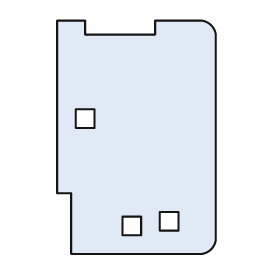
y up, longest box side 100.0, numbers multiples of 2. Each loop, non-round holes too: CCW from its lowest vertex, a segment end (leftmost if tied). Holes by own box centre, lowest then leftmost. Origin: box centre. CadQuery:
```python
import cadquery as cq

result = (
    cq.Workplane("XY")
    .moveTo(-28.0, -50.0)
    .lineTo(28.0, -50.0)
    .threePointArc((32.0, -48.0), (34.0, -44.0))
    .lineTo(34.0, 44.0)
    .threePointArc((32.0, 48.0), (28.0, 50.0))
    .lineTo(8.0, 50.0)
    .lineTo(8.0, 44.0)
    .lineTo(-22.0, 44.0)
    .lineTo(-22.0, 50.0)
    .lineTo(-34.0, 50.0)
    .lineTo(-34.0, -24.0)
    .lineTo(-28.0, -24.0)
    .close()
    .moveTo(-6.0, -42.0)
    .lineTo(2.0, -42.0)
    .lineTo(2.0, -34.0)
    .lineTo(-6.0, -34.0)
    .close()
    .moveTo(10.0, -40.0)
    .lineTo(18.0, -40.0)
    .lineTo(18.0, -32.0)
    .lineTo(10.0, -32.0)
    .close()
    .moveTo(-26.0, 4.0)
    .lineTo(-18.0, 4.0)
    .lineTo(-18.0, 12.0)
    .lineTo(-26.0, 12.0)
    .close()
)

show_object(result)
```